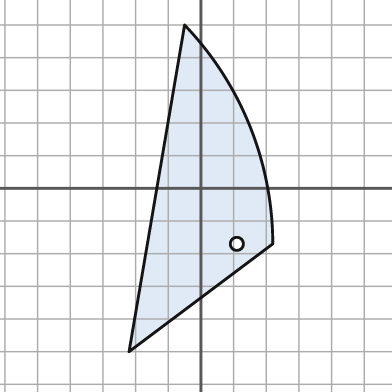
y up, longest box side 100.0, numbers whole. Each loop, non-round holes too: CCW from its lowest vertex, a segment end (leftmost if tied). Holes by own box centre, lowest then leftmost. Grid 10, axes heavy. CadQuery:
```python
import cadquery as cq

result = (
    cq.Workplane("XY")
    .moveTo(-22.0, -50.0)
    .lineTo(22.0, -17.0)
    .threePointArc((15.0, 19.0), (-5.0, 50.0))
    .close()
    .moveTo(11.0, -17.0)
    .circle(2.0)
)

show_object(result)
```